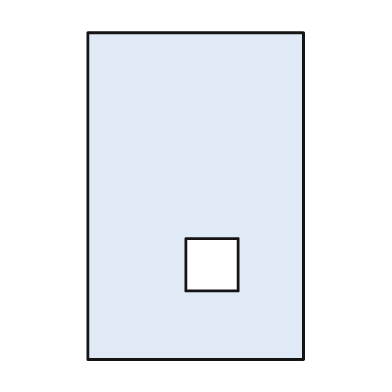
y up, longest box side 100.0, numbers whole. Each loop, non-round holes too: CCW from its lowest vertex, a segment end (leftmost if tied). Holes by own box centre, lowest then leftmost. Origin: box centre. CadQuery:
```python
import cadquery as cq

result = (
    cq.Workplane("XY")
    .moveTo(-33.0, -50.0)
    .lineTo(33.0, -50.0)
    .lineTo(33.0, 50.0)
    .lineTo(-33.0, 50.0)
    .close()
    .moveTo(-3.0, -29.0)
    .lineTo(13.0, -29.0)
    .lineTo(13.0, -13.0)
    .lineTo(-3.0, -13.0)
    .close()
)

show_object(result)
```